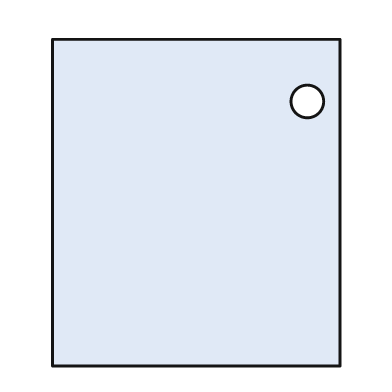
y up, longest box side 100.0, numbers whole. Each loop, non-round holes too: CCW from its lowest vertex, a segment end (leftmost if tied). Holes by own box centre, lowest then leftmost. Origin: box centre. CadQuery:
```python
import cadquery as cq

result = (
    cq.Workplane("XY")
    .moveTo(-44.0, -50.0)
    .lineTo(44.0, -50.0)
    .lineTo(44.0, 50.0)
    .lineTo(-44.0, 50.0)
    .close()
    .moveTo(34.0, 31.0)
    .circle(5.0)
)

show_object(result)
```